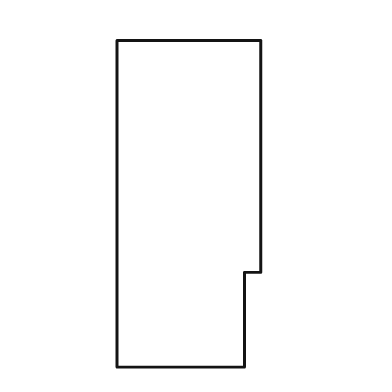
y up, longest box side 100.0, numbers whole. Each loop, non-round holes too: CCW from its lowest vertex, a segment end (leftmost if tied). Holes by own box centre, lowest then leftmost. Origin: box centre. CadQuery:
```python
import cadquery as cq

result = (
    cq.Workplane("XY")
    .moveTo(-22.0, -50.0)
    .lineTo(17.0, -50.0)
    .lineTo(17.0, -21.0)
    .lineTo(22.0, -21.0)
    .lineTo(22.0, 50.0)
    .lineTo(-22.0, 50.0)
    .close()
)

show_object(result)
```